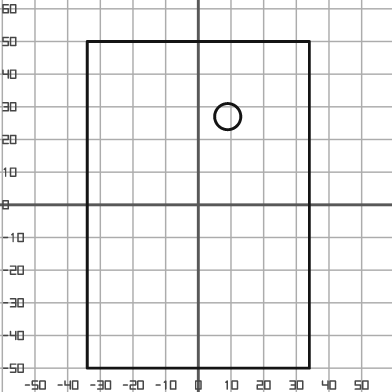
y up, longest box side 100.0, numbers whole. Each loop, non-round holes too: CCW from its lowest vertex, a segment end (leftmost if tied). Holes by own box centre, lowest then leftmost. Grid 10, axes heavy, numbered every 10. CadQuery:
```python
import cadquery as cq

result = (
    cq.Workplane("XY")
    .moveTo(-34.0, -50.0)
    .lineTo(34.0, -50.0)
    .lineTo(34.0, 50.0)
    .lineTo(-34.0, 50.0)
    .close()
    .moveTo(9.0, 27.0)
    .circle(4.0)
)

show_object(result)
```